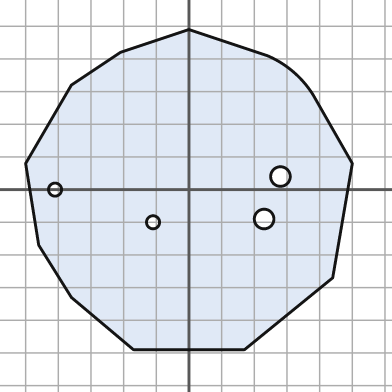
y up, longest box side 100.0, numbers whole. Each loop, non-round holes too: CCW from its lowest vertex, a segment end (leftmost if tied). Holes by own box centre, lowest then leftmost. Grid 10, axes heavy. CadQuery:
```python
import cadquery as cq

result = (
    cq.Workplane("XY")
    .moveTo(-17.0, -49.0)
    .lineTo(17.0, -49.0)
    .lineTo(44.0, -27.0)
    .lineTo(50.0, 8.0)
    .lineTo(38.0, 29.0)
    .threePointArc((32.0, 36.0), (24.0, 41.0))
    .lineTo(0.0, 49.0)
    .lineTo(-21.0, 42.0)
    .lineTo(-36.0, 32.0)
    .lineTo(-50.0, 8.0)
    .lineTo(-46.0, -17.0)
    .lineTo(-36.0, -33.0)
    .close()
    .moveTo(-11.0, -10.0)
    .circle(2.0)
    .moveTo(23.0, -9.0)
    .circle(3.0)
    .moveTo(-41.0, 0.0)
    .circle(2.0)
    .moveTo(28.0, 4.0)
    .circle(3.0)
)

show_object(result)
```